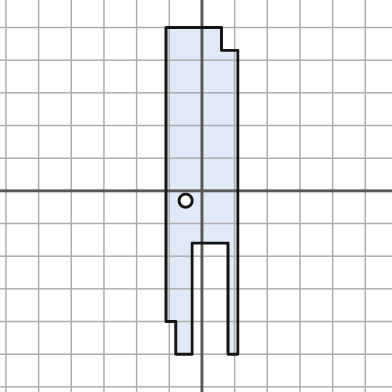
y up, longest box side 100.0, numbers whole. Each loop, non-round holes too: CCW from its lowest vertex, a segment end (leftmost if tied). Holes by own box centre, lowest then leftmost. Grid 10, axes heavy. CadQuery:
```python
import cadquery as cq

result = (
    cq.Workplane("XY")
    .moveTo(-8.0, -50.0)
    .lineTo(-3.0, -50.0)
    .lineTo(-3.0, -16.0)
    .lineTo(8.0, -16.0)
    .lineTo(8.0, -50.0)
    .lineTo(11.0, -50.0)
    .lineTo(11.0, 43.0)
    .lineTo(6.0, 43.0)
    .lineTo(6.0, 50.0)
    .lineTo(-11.0, 50.0)
    .lineTo(-11.0, -40.0)
    .lineTo(-8.0, -40.0)
    .close()
    .moveTo(-5.0, -3.0)
    .circle(2.0)
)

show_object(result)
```